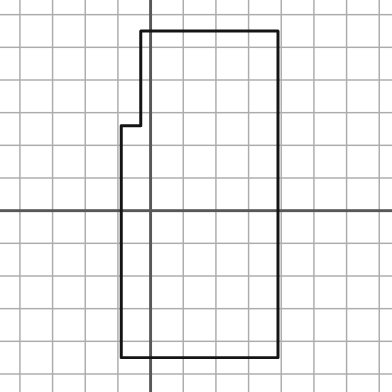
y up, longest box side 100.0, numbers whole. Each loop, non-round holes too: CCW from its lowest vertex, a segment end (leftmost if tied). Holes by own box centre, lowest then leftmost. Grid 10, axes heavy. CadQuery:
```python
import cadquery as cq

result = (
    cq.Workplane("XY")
    .moveTo(-9.0, -45.0)
    .lineTo(39.0, -45.0)
    .lineTo(39.0, 55.0)
    .lineTo(-3.0, 55.0)
    .lineTo(-3.0, 26.0)
    .lineTo(-9.0, 26.0)
    .close()
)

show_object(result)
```